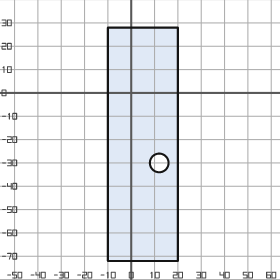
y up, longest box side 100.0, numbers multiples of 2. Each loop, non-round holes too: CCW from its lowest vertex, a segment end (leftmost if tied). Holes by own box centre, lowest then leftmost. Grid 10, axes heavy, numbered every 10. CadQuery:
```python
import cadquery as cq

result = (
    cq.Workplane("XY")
    .moveTo(-10.0, -72.0)
    .lineTo(20.0, -72.0)
    .lineTo(20.0, 28.0)
    .lineTo(-10.0, 28.0)
    .close()
    .moveTo(12.0, -30.0)
    .circle(4.0)
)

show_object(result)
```